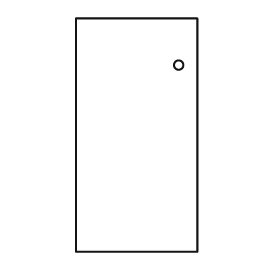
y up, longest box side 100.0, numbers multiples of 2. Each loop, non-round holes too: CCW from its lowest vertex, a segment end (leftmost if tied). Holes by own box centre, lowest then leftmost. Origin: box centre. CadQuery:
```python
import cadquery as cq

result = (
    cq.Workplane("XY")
    .moveTo(-26.0, -50.0)
    .lineTo(26.0, -50.0)
    .lineTo(26.0, 50.0)
    .lineTo(-26.0, 50.0)
    .close()
    .moveTo(18.0, 30.0)
    .circle(2.0)
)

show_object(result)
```